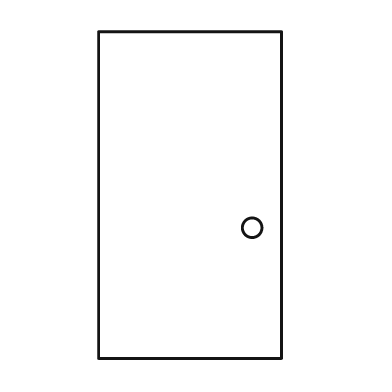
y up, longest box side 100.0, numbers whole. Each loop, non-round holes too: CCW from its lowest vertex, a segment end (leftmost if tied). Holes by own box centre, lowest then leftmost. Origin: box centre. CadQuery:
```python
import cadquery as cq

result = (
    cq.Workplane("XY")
    .moveTo(-28.0, -50.0)
    .lineTo(28.0, -50.0)
    .lineTo(28.0, 50.0)
    .lineTo(-28.0, 50.0)
    .close()
    .moveTo(19.0, -10.0)
    .circle(3.0)
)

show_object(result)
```